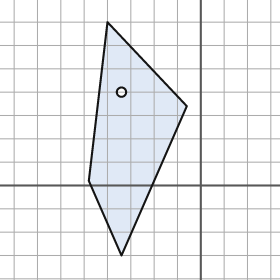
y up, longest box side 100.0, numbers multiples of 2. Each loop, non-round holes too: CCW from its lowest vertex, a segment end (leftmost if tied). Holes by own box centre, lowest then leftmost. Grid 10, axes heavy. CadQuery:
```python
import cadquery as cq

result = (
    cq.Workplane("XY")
    .moveTo(-34.0, -30.0)
    .lineTo(-6.0, 34.0)
    .lineTo(-40.0, 70.0)
    .lineTo(-48.0, 2.0)
    .close()
    .moveTo(-34.0, 40.0)
    .circle(2.0)
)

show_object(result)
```